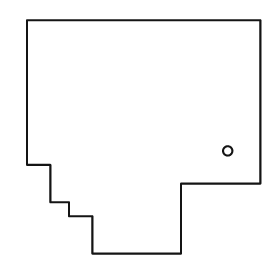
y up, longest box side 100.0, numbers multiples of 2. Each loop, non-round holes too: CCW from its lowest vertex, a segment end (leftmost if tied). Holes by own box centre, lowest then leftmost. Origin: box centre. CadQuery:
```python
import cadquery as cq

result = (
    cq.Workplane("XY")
    .moveTo(-22.0, -50.0)
    .lineTo(16.0, -50.0)
    .lineTo(16.0, -20.0)
    .lineTo(50.0, -20.0)
    .lineTo(50.0, 50.0)
    .lineTo(-50.0, 50.0)
    .lineTo(-50.0, -12.0)
    .lineTo(-40.0, -12.0)
    .lineTo(-40.0, -28.0)
    .lineTo(-32.0, -28.0)
    .lineTo(-32.0, -34.0)
    .lineTo(-22.0, -34.0)
    .close()
    .moveTo(36.0, -6.0)
    .circle(2.0)
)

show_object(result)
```